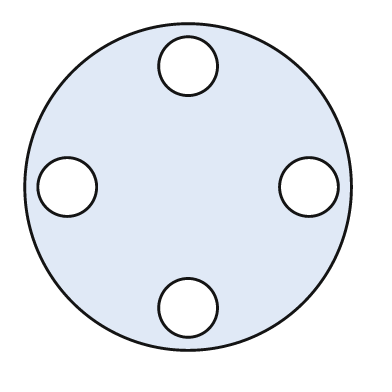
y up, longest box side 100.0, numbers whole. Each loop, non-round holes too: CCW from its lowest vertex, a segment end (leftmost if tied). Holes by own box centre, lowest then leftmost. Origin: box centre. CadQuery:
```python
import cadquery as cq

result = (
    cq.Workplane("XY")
    .moveTo(0.0, 0.0)
    .circle(50.0)
    .moveTo(0.0, -37.0)
    .circle(9.0)
    .moveTo(-37.0, 0.0)
    .circle(9.0)
    .moveTo(37.0, 0.0)
    .circle(9.0)
    .moveTo(0.0, 37.0)
    .circle(9.0)
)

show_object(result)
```